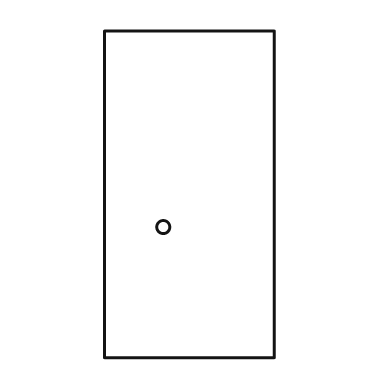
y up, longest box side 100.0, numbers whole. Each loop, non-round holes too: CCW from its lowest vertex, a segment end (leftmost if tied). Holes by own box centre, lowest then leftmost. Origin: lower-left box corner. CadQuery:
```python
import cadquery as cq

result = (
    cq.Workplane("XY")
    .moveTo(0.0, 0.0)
    .lineTo(52.0, 0.0)
    .lineTo(52.0, 100.0)
    .lineTo(0.0, 100.0)
    .close()
    .moveTo(18.0, 40.0)
    .circle(2.0)
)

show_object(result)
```